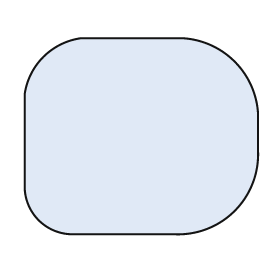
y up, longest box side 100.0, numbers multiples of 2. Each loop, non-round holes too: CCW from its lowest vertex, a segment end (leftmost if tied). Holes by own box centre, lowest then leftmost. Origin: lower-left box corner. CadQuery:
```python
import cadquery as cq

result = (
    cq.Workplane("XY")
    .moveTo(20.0, 0.0)
    .lineTo(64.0, 0.0)
    .threePointArc((90.0, 10.0), (100.0, 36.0))
    .lineTo(100.0, 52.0)
    .threePointArc((90.0, 74.0), (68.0, 84.0))
    .lineTo(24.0, 84.0)
    .threePointArc((8.0, 76.0), (0.0, 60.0))
    .lineTo(0.0, 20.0)
    .threePointArc((6.0, 6.0), (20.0, 0.0))
    .close()
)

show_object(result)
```